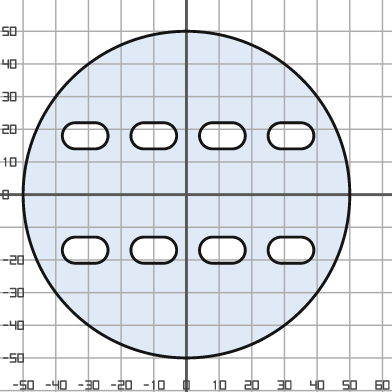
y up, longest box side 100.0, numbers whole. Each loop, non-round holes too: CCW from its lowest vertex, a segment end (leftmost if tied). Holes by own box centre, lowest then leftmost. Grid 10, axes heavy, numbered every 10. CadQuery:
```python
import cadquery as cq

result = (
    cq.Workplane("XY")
    .moveTo(0.0, 0.0)
    .circle(50.0)
    .moveTo(-34.0, -21.0)
    .lineTo(-28.0, -21.0)
    .threePointArc((-24.0, -17.0), (-28.0, -13.0))
    .lineTo(-34.0, -13.0)
    .threePointArc((-38.0, -17.0), (-34.0, -21.0))
    .close()
    .moveTo(-13.0, -21.0)
    .lineTo(-7.0, -21.0)
    .threePointArc((-3.0, -17.0), (-7.0, -13.0))
    .lineTo(-13.0, -13.0)
    .threePointArc((-17.0, -17.0), (-13.0, -21.0))
    .close()
    .moveTo(8.0, -21.0)
    .lineTo(14.0, -21.0)
    .threePointArc((18.0, -17.0), (14.0, -13.0))
    .lineTo(8.0, -13.0)
    .threePointArc((4.0, -17.0), (8.0, -21.0))
    .close()
    .moveTo(29.0, -21.0)
    .lineTo(35.0, -21.0)
    .threePointArc((39.0, -17.0), (35.0, -13.0))
    .lineTo(29.0, -13.0)
    .threePointArc((25.0, -17.0), (29.0, -21.0))
    .close()
    .moveTo(-34.0, 14.0)
    .lineTo(-28.0, 14.0)
    .threePointArc((-24.0, 18.0), (-28.0, 22.0))
    .lineTo(-34.0, 22.0)
    .threePointArc((-38.0, 18.0), (-34.0, 14.0))
    .close()
    .moveTo(-13.0, 14.0)
    .lineTo(-7.0, 14.0)
    .threePointArc((-3.0, 18.0), (-7.0, 22.0))
    .lineTo(-13.0, 22.0)
    .threePointArc((-17.0, 18.0), (-13.0, 14.0))
    .close()
    .moveTo(8.0, 14.0)
    .lineTo(14.0, 14.0)
    .threePointArc((18.0, 18.0), (14.0, 22.0))
    .lineTo(8.0, 22.0)
    .threePointArc((4.0, 18.0), (8.0, 14.0))
    .close()
    .moveTo(29.0, 14.0)
    .lineTo(35.0, 14.0)
    .threePointArc((39.0, 18.0), (35.0, 22.0))
    .lineTo(29.0, 22.0)
    .threePointArc((25.0, 18.0), (29.0, 14.0))
    .close()
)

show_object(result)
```